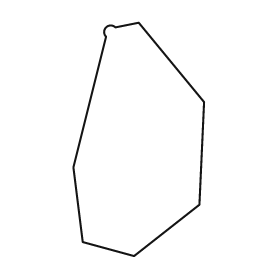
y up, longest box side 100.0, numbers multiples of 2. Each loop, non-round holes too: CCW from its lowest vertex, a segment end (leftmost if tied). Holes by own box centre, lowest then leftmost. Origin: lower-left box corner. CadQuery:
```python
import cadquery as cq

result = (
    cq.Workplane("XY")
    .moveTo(26.0, 0.0)
    .lineTo(54.0, 22.0)
    .lineTo(56.0, 66.0)
    .lineTo(28.0, 100.0)
    .lineTo(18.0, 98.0)
    .threePointArc((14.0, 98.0), (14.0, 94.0))
    .lineTo(0.0, 38.0)
    .lineTo(4.0, 6.0)
    .close()
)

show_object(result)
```